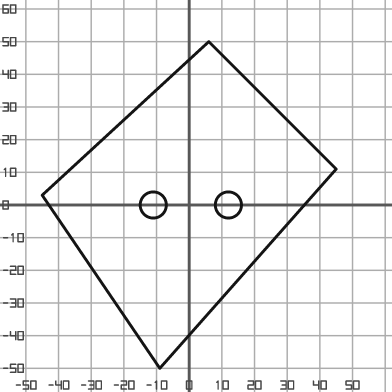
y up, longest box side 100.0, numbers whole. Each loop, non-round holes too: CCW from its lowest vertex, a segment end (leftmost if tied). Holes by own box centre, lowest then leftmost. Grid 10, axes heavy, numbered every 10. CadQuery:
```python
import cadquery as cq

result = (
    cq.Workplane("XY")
    .moveTo(-9.0, -50.0)
    .lineTo(45.0, 11.0)
    .lineTo(6.0, 50.0)
    .lineTo(-45.0, 3.0)
    .close()
    .moveTo(-11.0, 0.0)
    .circle(4.0)
    .moveTo(12.0, 0.0)
    .circle(4.0)
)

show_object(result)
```